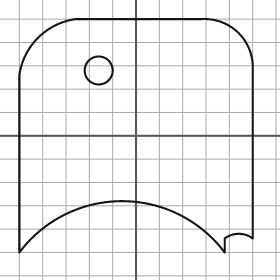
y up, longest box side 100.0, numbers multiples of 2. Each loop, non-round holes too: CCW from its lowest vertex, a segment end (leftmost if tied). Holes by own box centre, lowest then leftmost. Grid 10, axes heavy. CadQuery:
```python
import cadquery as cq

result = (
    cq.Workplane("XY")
    .moveTo(-50.0, -50.0)
    .threePointArc((-6.0, -28.0), (38.0, -50.0))
    .lineTo(38.0, -44.0)
    .threePointArc((44.0, -42.0), (50.0, -44.0))
    .lineTo(50.0, 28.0)
    .threePointArc((44.0, 44.0), (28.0, 50.0))
    .lineTo(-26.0, 50.0)
    .threePointArc((-42.0, 42.0), (-50.0, 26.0))
    .close()
    .moveTo(-16.0, 28.0)
    .circle(6.0)
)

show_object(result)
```